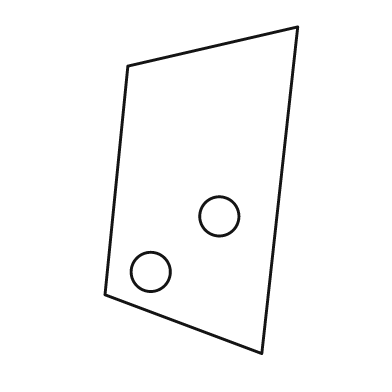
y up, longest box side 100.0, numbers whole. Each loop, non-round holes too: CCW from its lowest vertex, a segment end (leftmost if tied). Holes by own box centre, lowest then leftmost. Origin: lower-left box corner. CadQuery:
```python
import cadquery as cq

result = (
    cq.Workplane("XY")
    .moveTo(48.0, 0.0)
    .lineTo(59.0, 100.0)
    .lineTo(7.0, 88.0)
    .lineTo(0.0, 18.0)
    .close()
    .moveTo(14.0, 25.0)
    .circle(6.0)
    .moveTo(35.0, 42.0)
    .circle(6.0)
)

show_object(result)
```